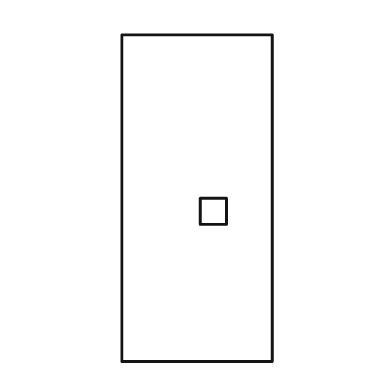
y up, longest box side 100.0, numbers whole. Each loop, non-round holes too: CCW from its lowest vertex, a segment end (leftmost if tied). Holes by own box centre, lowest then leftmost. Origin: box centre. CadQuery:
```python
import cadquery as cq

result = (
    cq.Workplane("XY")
    .moveTo(-23.0, -50.0)
    .lineTo(23.0, -50.0)
    .lineTo(23.0, 50.0)
    .lineTo(-23.0, 50.0)
    .close()
    .moveTo(1.0, -8.0)
    .lineTo(9.0, -8.0)
    .lineTo(9.0, 0.0)
    .lineTo(1.0, 0.0)
    .close()
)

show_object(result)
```